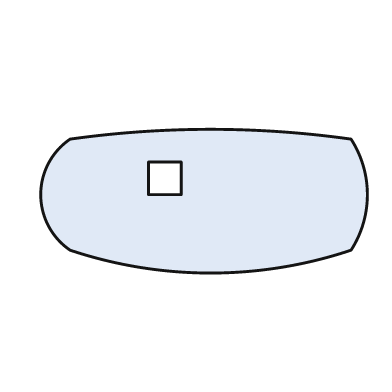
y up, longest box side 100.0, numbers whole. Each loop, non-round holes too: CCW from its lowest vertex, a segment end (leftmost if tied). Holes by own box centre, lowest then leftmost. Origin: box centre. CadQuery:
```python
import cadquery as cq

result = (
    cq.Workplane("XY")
    .moveTo(-41.0, -15.0)
    .threePointArc((2.0, -22.0), (45.0, -15.0))
    .threePointArc((50.0, 2.0), (45.0, 19.0))
    .threePointArc((2.0, 22.0), (-41.0, 19.0))
    .threePointArc((-50.0, 2.0), (-41.0, -15.0))
    .close()
    .moveTo(-17.0, 2.0)
    .lineTo(-7.0, 2.0)
    .lineTo(-7.0, 12.0)
    .lineTo(-17.0, 12.0)
    .close()
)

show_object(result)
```